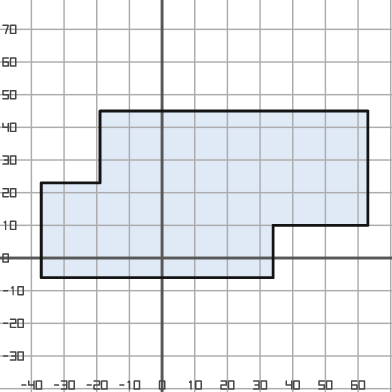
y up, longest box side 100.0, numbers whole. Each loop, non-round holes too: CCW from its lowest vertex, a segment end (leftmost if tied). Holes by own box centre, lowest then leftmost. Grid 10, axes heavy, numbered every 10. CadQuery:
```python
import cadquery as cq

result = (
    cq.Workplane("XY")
    .moveTo(-37.0, -6.0)
    .lineTo(34.0, -6.0)
    .lineTo(34.0, 10.0)
    .lineTo(63.0, 10.0)
    .lineTo(63.0, 45.0)
    .lineTo(-19.0, 45.0)
    .lineTo(-19.0, 23.0)
    .lineTo(-37.0, 23.0)
    .close()
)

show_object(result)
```